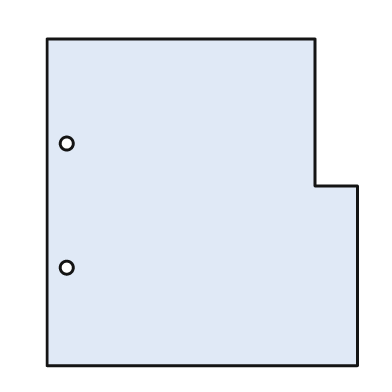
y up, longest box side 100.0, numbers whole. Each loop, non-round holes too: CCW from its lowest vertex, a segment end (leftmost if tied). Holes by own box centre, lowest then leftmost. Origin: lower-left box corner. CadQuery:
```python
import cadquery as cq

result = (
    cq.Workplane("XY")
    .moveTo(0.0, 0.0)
    .lineTo(95.0, 0.0)
    .lineTo(95.0, 55.0)
    .lineTo(82.0, 55.0)
    .lineTo(82.0, 100.0)
    .lineTo(0.0, 100.0)
    .close()
    .moveTo(6.0, 30.0)
    .circle(2.0)
    .moveTo(6.0, 68.0)
    .circle(2.0)
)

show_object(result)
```